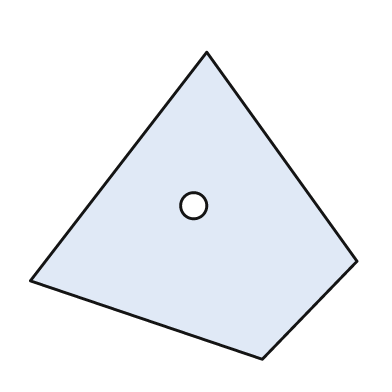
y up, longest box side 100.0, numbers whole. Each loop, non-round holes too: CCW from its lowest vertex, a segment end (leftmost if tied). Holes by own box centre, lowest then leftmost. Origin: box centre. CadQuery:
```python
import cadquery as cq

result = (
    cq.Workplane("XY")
    .moveTo(21.0, -47.0)
    .lineTo(50.0, -17.0)
    .lineTo(4.0, 47.0)
    .lineTo(-50.0, -23.0)
    .close()
    .moveTo(0.0, 0.0)
    .circle(4.0)
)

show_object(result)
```